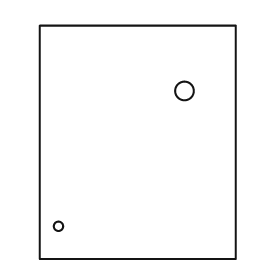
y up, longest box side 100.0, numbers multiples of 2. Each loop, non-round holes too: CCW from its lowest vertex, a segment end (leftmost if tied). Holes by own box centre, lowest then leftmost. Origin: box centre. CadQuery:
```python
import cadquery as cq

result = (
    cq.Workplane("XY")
    .moveTo(-42.0, -50.0)
    .lineTo(42.0, -50.0)
    .lineTo(42.0, 50.0)
    .lineTo(-42.0, 50.0)
    .close()
    .moveTo(-34.0, -36.0)
    .circle(2.0)
    .moveTo(20.0, 22.0)
    .circle(4.0)
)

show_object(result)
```